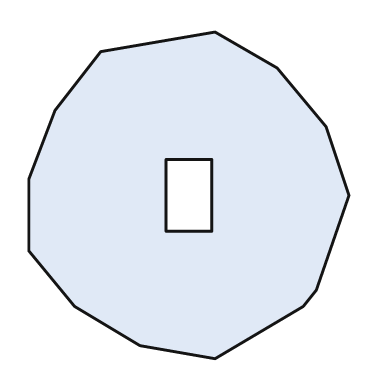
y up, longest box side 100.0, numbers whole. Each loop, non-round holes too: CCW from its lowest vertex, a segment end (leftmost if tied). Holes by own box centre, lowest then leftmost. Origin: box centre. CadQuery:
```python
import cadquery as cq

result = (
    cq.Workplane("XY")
    .moveTo(8.0, -50.0)
    .lineTo(35.0, -34.0)
    .lineTo(39.0, -29.0)
    .lineTo(49.0, 0.0)
    .lineTo(42.0, 21.0)
    .lineTo(27.0, 39.0)
    .lineTo(8.0, 50.0)
    .lineTo(-27.0, 44.0)
    .lineTo(-41.0, 26.0)
    .lineTo(-49.0, 5.0)
    .lineTo(-49.0, -17.0)
    .lineTo(-35.0, -34.0)
    .lineTo(-15.0, -46.0)
    .close()
    .moveTo(-7.0, -11.0)
    .lineTo(7.0, -11.0)
    .lineTo(7.0, 11.0)
    .lineTo(-7.0, 11.0)
    .close()
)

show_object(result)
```